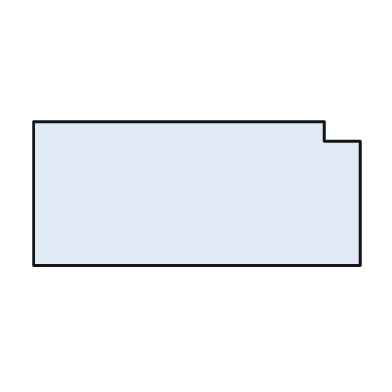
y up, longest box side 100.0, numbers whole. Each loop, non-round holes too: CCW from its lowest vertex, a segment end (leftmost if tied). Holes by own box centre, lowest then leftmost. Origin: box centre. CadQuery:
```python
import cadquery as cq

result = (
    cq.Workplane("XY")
    .moveTo(-50.0, -22.0)
    .lineTo(50.0, -22.0)
    .lineTo(50.0, 16.0)
    .lineTo(39.0, 16.0)
    .lineTo(39.0, 22.0)
    .lineTo(-50.0, 22.0)
    .close()
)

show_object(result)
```